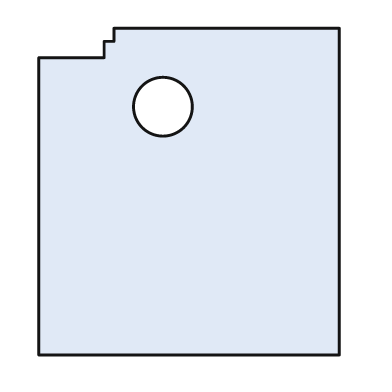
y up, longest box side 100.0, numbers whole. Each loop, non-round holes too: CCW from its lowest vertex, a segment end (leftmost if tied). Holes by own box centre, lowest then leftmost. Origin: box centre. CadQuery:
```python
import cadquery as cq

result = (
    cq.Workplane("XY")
    .moveTo(-46.0, -50.0)
    .lineTo(46.0, -50.0)
    .lineTo(46.0, 50.0)
    .lineTo(-23.0, 50.0)
    .lineTo(-23.0, 46.0)
    .lineTo(-26.0, 46.0)
    .lineTo(-26.0, 41.0)
    .lineTo(-46.0, 41.0)
    .close()
    .moveTo(-8.0, 26.0)
    .circle(9.0)
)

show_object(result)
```